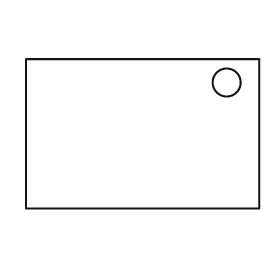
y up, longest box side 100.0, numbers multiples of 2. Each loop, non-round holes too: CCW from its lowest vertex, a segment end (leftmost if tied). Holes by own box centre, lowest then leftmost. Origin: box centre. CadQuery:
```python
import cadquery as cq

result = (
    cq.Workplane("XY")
    .moveTo(-50.0, -32.0)
    .lineTo(50.0, -32.0)
    .lineTo(50.0, 32.0)
    .lineTo(-50.0, 32.0)
    .close()
    .moveTo(36.0, 22.0)
    .circle(6.0)
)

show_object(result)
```